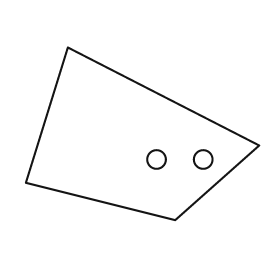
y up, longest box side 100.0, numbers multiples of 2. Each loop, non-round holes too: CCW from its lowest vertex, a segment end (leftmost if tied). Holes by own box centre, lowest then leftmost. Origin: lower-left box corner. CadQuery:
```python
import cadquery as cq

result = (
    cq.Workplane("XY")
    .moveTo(64.0, 0.0)
    .lineTo(100.0, 32.0)
    .lineTo(18.0, 74.0)
    .lineTo(0.0, 16.0)
    .close()
    .moveTo(56.0, 26.0)
    .circle(4.0)
    .moveTo(76.0, 26.0)
    .circle(4.0)
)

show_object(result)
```